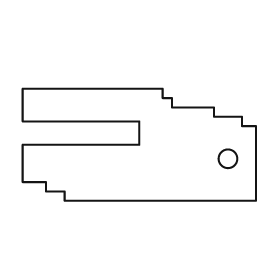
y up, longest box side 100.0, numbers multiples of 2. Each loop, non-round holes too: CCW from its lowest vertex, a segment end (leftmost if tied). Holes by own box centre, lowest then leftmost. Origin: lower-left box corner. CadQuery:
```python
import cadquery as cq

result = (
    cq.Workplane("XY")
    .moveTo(18.0, 0.0)
    .lineTo(100.0, 0.0)
    .lineTo(100.0, 32.0)
    .lineTo(94.0, 32.0)
    .lineTo(94.0, 36.0)
    .lineTo(82.0, 36.0)
    .lineTo(82.0, 40.0)
    .lineTo(64.0, 40.0)
    .lineTo(64.0, 44.0)
    .lineTo(60.0, 44.0)
    .lineTo(60.0, 48.0)
    .lineTo(0.0, 48.0)
    .lineTo(0.0, 34.0)
    .lineTo(50.0, 34.0)
    .lineTo(50.0, 24.0)
    .lineTo(0.0, 24.0)
    .lineTo(0.0, 8.0)
    .lineTo(10.0, 8.0)
    .lineTo(10.0, 4.0)
    .lineTo(18.0, 4.0)
    .close()
    .moveTo(88.0, 18.0)
    .circle(4.0)
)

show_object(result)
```